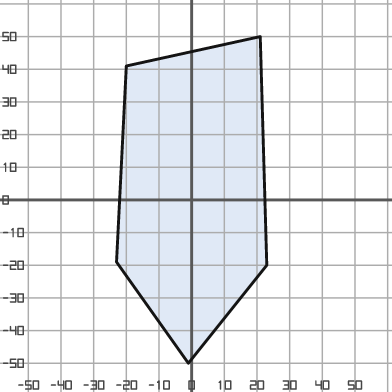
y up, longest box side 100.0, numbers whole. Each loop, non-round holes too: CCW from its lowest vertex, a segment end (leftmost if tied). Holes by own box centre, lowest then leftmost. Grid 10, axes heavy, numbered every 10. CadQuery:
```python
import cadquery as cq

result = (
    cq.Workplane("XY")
    .moveTo(-1.0, -50.0)
    .lineTo(23.0, -20.0)
    .lineTo(21.0, 50.0)
    .lineTo(-20.0, 41.0)
    .lineTo(-23.0, -19.0)
    .close()
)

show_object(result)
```